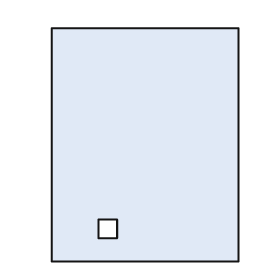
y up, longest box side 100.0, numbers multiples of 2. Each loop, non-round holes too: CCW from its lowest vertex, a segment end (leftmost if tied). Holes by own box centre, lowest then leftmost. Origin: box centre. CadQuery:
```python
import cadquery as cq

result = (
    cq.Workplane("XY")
    .moveTo(-40.0, -50.0)
    .lineTo(40.0, -50.0)
    .lineTo(40.0, 50.0)
    .lineTo(-40.0, 50.0)
    .close()
    .moveTo(-20.0, -40.0)
    .lineTo(-12.0, -40.0)
    .lineTo(-12.0, -32.0)
    .lineTo(-20.0, -32.0)
    .close()
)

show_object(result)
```